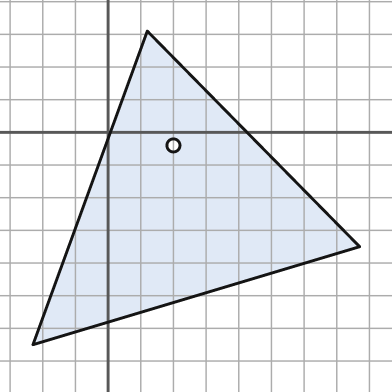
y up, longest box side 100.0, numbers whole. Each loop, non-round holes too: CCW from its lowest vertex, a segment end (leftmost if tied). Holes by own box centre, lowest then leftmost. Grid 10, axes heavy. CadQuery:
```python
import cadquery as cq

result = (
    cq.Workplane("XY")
    .moveTo(-23.0, -65.0)
    .lineTo(77.0, -35.0)
    .lineTo(12.0, 31.0)
    .close()
    .moveTo(20.0, -4.0)
    .circle(2.0)
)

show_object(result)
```